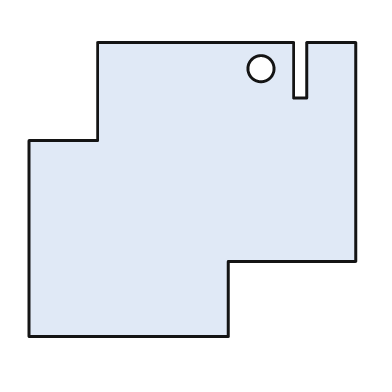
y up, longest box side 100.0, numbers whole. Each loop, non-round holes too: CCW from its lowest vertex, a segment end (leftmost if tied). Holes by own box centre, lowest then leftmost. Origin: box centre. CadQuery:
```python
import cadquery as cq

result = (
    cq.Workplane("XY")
    .moveTo(-50.0, -45.0)
    .lineTo(11.0, -45.0)
    .lineTo(11.0, -22.0)
    .lineTo(50.0, -22.0)
    .lineTo(50.0, 45.0)
    .lineTo(35.0, 45.0)
    .lineTo(35.0, 28.0)
    .lineTo(31.0, 28.0)
    .lineTo(31.0, 45.0)
    .lineTo(-29.0, 45.0)
    .lineTo(-29.0, 15.0)
    .lineTo(-50.0, 15.0)
    .close()
    .moveTo(21.0, 37.0)
    .circle(4.0)
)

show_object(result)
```